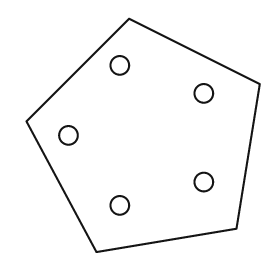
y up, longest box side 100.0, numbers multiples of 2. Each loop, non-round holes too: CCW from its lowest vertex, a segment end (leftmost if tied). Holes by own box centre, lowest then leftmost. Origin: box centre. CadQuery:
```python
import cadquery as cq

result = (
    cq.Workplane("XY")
    .moveTo(-20.0, -50.0)
    .lineTo(40.0, -40.0)
    .lineTo(50.0, 22.0)
    .lineTo(-6.0, 50.0)
    .lineTo(-50.0, 6.0)
    .close()
    .moveTo(-10.0, -30.0)
    .circle(4.0)
    .moveTo(26.0, -20.0)
    .circle(4.0)
    .moveTo(-32.0, 0.0)
    .circle(4.0)
    .moveTo(26.0, 18.0)
    .circle(4.0)
    .moveTo(-10.0, 30.0)
    .circle(4.0)
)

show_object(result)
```